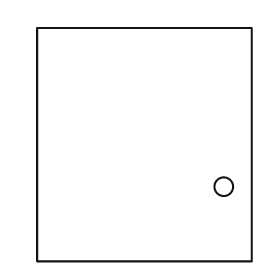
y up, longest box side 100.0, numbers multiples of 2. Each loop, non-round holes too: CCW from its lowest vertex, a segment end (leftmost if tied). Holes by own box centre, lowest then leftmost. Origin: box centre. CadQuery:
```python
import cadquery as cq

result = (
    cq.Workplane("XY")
    .moveTo(-46.0, -50.0)
    .lineTo(46.0, -50.0)
    .lineTo(46.0, 50.0)
    .lineTo(-46.0, 50.0)
    .close()
    .moveTo(34.0, -18.0)
    .circle(4.0)
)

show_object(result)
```